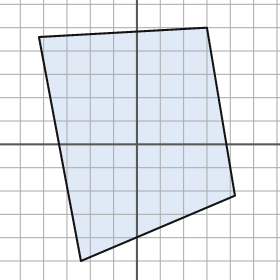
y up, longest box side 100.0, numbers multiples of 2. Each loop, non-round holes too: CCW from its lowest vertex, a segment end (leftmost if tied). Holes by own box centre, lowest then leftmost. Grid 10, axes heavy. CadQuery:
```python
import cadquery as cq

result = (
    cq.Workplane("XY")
    .moveTo(-24.0, -50.0)
    .lineTo(42.0, -22.0)
    .lineTo(30.0, 50.0)
    .lineTo(-42.0, 46.0)
    .close()
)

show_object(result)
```